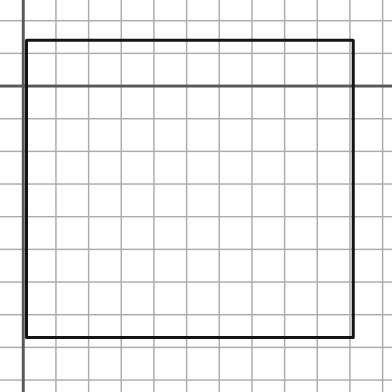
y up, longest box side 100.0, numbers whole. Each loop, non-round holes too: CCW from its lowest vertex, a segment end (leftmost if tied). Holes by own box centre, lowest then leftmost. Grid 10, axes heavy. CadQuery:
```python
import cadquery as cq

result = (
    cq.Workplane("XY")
    .moveTo(1.0, -77.0)
    .lineTo(101.0, -77.0)
    .lineTo(101.0, 14.0)
    .lineTo(1.0, 14.0)
    .close()
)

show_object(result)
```